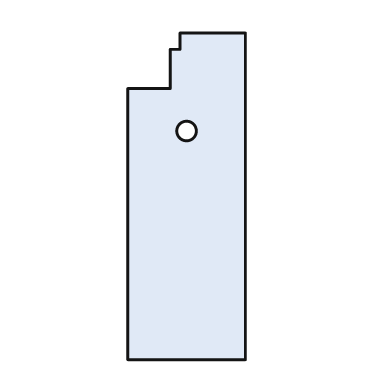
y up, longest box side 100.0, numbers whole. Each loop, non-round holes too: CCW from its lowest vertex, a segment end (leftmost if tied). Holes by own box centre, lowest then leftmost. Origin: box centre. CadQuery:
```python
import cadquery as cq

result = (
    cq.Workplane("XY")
    .moveTo(-18.0, -50.0)
    .lineTo(18.0, -50.0)
    .lineTo(18.0, 50.0)
    .lineTo(-2.0, 50.0)
    .lineTo(-2.0, 45.0)
    .lineTo(-5.0, 45.0)
    .lineTo(-5.0, 33.0)
    .lineTo(-18.0, 33.0)
    .close()
    .moveTo(0.0, 20.0)
    .circle(3.0)
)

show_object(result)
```